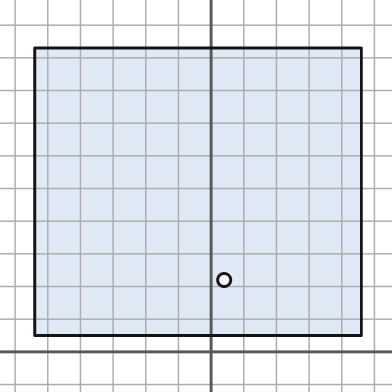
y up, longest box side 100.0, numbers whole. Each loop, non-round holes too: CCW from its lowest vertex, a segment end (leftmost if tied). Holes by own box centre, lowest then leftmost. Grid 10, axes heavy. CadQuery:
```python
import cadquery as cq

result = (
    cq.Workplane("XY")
    .moveTo(-54.0, 5.0)
    .lineTo(46.0, 5.0)
    .lineTo(46.0, 93.0)
    .lineTo(-54.0, 93.0)
    .close()
    .moveTo(4.0, 22.0)
    .circle(2.0)
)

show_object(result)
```